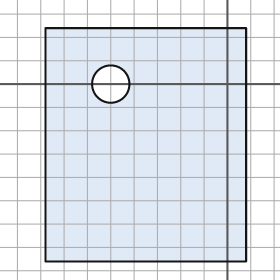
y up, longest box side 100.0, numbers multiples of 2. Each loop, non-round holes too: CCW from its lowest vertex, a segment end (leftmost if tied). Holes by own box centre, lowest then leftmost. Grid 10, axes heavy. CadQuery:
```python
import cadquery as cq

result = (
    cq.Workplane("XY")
    .moveTo(-78.0, -76.0)
    .lineTo(8.0, -76.0)
    .lineTo(8.0, 24.0)
    .lineTo(-78.0, 24.0)
    .close()
    .moveTo(-50.0, 0.0)
    .circle(8.0)
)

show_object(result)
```